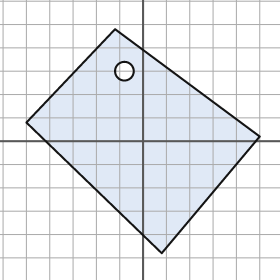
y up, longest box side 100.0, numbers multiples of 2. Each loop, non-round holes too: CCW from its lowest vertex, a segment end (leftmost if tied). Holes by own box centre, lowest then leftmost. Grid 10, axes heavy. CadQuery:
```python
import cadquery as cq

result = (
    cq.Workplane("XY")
    .moveTo(8.0, -48.0)
    .lineTo(50.0, 2.0)
    .lineTo(-12.0, 48.0)
    .lineTo(-50.0, 8.0)
    .close()
    .moveTo(-8.0, 30.0)
    .circle(4.0)
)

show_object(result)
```